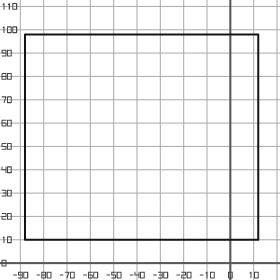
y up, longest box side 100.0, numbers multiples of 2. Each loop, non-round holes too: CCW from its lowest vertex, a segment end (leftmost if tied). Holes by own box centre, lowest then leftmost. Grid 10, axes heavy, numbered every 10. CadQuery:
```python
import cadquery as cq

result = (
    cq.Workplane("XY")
    .moveTo(-88.0, 10.0)
    .lineTo(12.0, 10.0)
    .lineTo(12.0, 98.0)
    .lineTo(-88.0, 98.0)
    .close()
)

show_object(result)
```